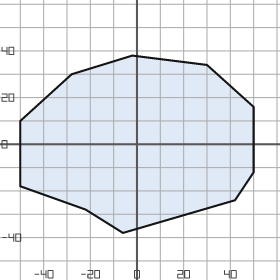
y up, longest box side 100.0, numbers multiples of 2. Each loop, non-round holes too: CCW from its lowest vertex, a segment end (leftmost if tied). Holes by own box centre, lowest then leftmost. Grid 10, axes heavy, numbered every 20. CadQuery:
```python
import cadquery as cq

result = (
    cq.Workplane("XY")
    .moveTo(-6.0, -38.0)
    .lineTo(42.0, -24.0)
    .lineTo(50.0, -12.0)
    .lineTo(50.0, 16.0)
    .lineTo(30.0, 34.0)
    .lineTo(-2.0, 38.0)
    .lineTo(-28.0, 30.0)
    .lineTo(-50.0, 10.0)
    .lineTo(-50.0, -18.0)
    .lineTo(-22.0, -28.0)
    .close()
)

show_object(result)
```